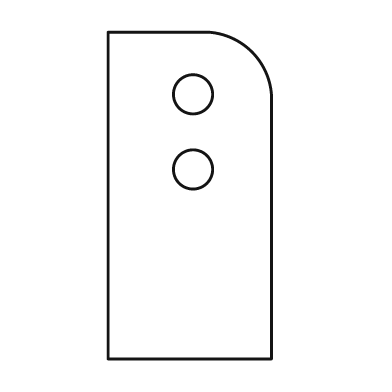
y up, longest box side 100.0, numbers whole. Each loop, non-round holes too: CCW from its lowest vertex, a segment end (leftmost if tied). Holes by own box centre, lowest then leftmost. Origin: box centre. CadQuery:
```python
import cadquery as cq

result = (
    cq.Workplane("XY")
    .moveTo(-25.0, -50.0)
    .lineTo(25.0, -50.0)
    .lineTo(25.0, 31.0)
    .threePointArc((19.0, 44.0), (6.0, 50.0))
    .lineTo(-25.0, 50.0)
    .close()
    .moveTo(1.0, 8.0)
    .circle(6.0)
    .moveTo(1.0, 31.0)
    .circle(6.0)
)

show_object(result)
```